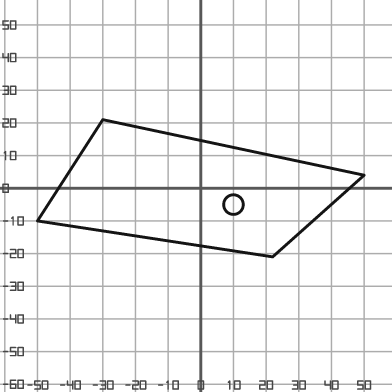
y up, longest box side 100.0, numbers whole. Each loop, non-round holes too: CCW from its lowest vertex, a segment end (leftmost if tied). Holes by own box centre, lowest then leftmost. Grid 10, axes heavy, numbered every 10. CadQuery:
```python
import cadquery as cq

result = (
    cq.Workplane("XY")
    .moveTo(22.0, -21.0)
    .lineTo(50.0, 4.0)
    .lineTo(-30.0, 21.0)
    .lineTo(-50.0, -10.0)
    .close()
    .moveTo(10.0, -5.0)
    .circle(3.0)
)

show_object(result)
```